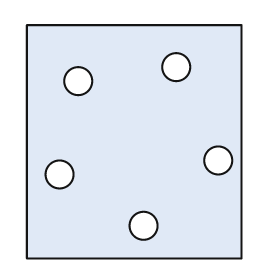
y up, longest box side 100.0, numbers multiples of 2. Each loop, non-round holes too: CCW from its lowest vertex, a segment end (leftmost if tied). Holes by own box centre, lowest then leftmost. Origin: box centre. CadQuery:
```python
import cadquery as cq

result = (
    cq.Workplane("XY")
    .moveTo(-46.0, -50.0)
    .lineTo(46.0, -50.0)
    .lineTo(46.0, 50.0)
    .lineTo(-46.0, 50.0)
    .close()
    .moveTo(4.0, -36.0)
    .circle(6.0)
    .moveTo(-32.0, -14.0)
    .circle(6.0)
    .moveTo(36.0, -8.0)
    .circle(6.0)
    .moveTo(-24.0, 26.0)
    .circle(6.0)
    .moveTo(18.0, 32.0)
    .circle(6.0)
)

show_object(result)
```